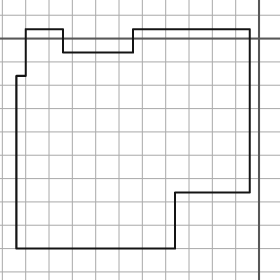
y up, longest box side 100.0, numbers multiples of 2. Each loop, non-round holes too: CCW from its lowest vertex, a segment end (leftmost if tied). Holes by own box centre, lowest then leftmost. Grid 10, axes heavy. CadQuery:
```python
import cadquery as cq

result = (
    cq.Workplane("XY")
    .moveTo(-104.0, -90.0)
    .lineTo(-36.0, -90.0)
    .lineTo(-36.0, -66.0)
    .lineTo(-4.0, -66.0)
    .lineTo(-4.0, 4.0)
    .lineTo(-54.0, 4.0)
    .lineTo(-54.0, -6.0)
    .lineTo(-84.0, -6.0)
    .lineTo(-84.0, 4.0)
    .lineTo(-100.0, 4.0)
    .lineTo(-100.0, -16.0)
    .lineTo(-104.0, -16.0)
    .close()
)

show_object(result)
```